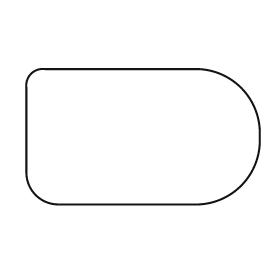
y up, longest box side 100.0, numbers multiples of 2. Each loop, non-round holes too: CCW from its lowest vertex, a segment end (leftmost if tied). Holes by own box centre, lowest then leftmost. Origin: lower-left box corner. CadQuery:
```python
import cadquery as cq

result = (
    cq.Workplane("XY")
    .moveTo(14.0, 0.0)
    .lineTo(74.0, 0.0)
    .threePointArc((92.0, 8.0), (100.0, 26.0))
    .lineTo(100.0, 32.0)
    .threePointArc((92.0, 50.0), (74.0, 58.0))
    .lineTo(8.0, 58.0)
    .threePointArc((2.0, 56.0), (0.0, 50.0))
    .lineTo(0.0, 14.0)
    .threePointArc((4.0, 4.0), (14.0, 0.0))
    .close()
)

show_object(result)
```